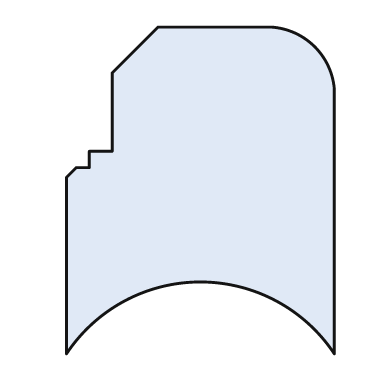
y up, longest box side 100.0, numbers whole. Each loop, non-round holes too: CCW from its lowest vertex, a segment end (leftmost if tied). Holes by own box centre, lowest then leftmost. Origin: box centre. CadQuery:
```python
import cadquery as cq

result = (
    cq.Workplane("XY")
    .moveTo(-41.0, -50.0)
    .threePointArc((0.0, -28.0), (41.0, -50.0))
    .lineTo(41.0, 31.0)
    .threePointArc((35.0, 44.0), (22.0, 50.0))
    .lineTo(-13.0, 50.0)
    .lineTo(-27.0, 36.0)
    .lineTo(-27.0, 12.0)
    .lineTo(-34.0, 12.0)
    .lineTo(-34.0, 7.0)
    .lineTo(-38.0, 7.0)
    .lineTo(-41.0, 4.0)
    .close()
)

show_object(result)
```